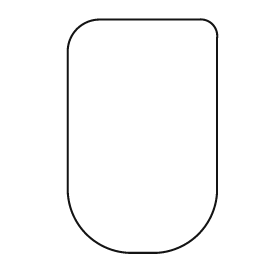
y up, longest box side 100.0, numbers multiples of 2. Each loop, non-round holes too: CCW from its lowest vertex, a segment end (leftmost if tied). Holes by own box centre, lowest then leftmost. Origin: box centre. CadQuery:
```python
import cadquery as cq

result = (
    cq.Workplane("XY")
    .moveTo(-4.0, -50.0)
    .lineTo(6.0, -50.0)
    .threePointArc((24.0, -42.0), (32.0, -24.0))
    .lineTo(32.0, 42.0)
    .threePointArc((30.0, 48.0), (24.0, 50.0))
    .lineTo(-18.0, 50.0)
    .threePointArc((-28.0, 46.0), (-32.0, 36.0))
    .lineTo(-32.0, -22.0)
    .threePointArc((-24.0, -42.0), (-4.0, -50.0))
    .close()
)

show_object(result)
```